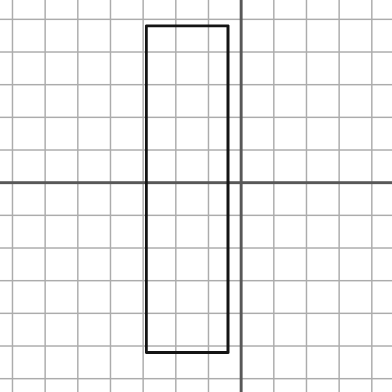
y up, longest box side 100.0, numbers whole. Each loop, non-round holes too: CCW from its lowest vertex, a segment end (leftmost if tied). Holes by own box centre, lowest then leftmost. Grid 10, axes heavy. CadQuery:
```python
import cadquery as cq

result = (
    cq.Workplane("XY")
    .moveTo(-29.0, -52.0)
    .lineTo(-4.0, -52.0)
    .lineTo(-4.0, 48.0)
    .lineTo(-29.0, 48.0)
    .close()
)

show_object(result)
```